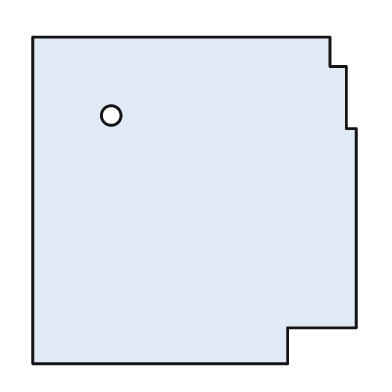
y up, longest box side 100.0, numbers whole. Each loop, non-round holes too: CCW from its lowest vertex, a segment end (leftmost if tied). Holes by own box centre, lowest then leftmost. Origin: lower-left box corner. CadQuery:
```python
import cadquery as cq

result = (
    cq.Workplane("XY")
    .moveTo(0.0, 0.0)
    .lineTo(78.0, 0.0)
    .lineTo(78.0, 11.0)
    .lineTo(99.0, 11.0)
    .lineTo(99.0, 72.0)
    .lineTo(96.0, 72.0)
    .lineTo(96.0, 91.0)
    .lineTo(91.0, 91.0)
    .lineTo(91.0, 100.0)
    .lineTo(0.0, 100.0)
    .close()
    .moveTo(24.0, 76.0)
    .circle(3.0)
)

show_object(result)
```